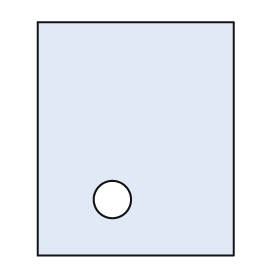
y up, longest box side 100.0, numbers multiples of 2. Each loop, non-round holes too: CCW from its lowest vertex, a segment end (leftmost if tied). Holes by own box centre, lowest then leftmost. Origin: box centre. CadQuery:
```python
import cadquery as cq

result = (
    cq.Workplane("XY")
    .moveTo(-42.0, -50.0)
    .lineTo(42.0, -50.0)
    .lineTo(42.0, 50.0)
    .lineTo(-42.0, 50.0)
    .close()
    .moveTo(-10.0, -26.0)
    .circle(8.0)
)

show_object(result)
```